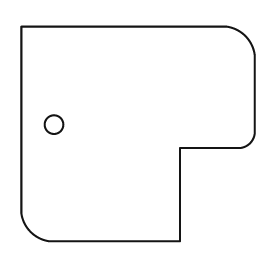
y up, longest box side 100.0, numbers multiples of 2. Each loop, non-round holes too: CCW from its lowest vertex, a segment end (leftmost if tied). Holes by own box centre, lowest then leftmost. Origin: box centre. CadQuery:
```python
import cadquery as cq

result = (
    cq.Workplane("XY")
    .moveTo(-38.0, -46.0)
    .lineTo(18.0, -46.0)
    .lineTo(18.0, -6.0)
    .lineTo(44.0, -6.0)
    .threePointArc((48.0, -4.0), (50.0, 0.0))
    .lineTo(50.0, 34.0)
    .threePointArc((46.0, 42.0), (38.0, 46.0))
    .lineTo(-50.0, 46.0)
    .lineTo(-50.0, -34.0)
    .threePointArc((-46.0, -42.0), (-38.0, -46.0))
    .close()
    .moveTo(-36.0, 4.0)
    .circle(4.0)
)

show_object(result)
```